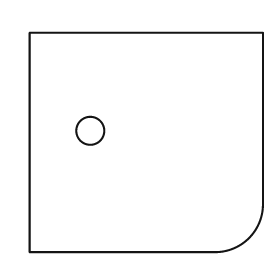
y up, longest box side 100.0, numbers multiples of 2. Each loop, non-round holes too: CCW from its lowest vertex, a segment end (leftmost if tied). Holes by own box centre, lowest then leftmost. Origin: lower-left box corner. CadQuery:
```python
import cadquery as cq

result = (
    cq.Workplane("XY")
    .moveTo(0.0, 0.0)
    .lineTo(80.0, 0.0)
    .threePointArc((94.0, 6.0), (100.0, 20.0))
    .lineTo(100.0, 94.0)
    .lineTo(0.0, 94.0)
    .close()
    .moveTo(26.0, 52.0)
    .circle(6.0)
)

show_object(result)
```